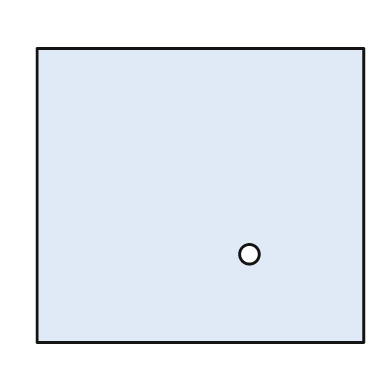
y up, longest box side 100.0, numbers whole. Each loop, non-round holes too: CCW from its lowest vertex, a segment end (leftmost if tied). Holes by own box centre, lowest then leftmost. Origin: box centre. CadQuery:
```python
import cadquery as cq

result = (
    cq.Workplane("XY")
    .moveTo(-50.0, -45.0)
    .lineTo(50.0, -45.0)
    .lineTo(50.0, 45.0)
    .lineTo(-50.0, 45.0)
    .close()
    .moveTo(15.0, -18.0)
    .circle(3.0)
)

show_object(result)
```